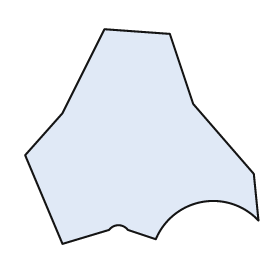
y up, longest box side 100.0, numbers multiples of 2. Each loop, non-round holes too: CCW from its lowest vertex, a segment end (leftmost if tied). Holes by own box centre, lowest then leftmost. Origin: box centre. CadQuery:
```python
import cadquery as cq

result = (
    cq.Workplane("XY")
    .moveTo(-34.0, -46.0)
    .lineTo(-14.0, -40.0)
    .threePointArc((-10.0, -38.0), (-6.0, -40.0))
    .lineTo(6.0, -44.0)
    .threePointArc((26.0, -28.0), (50.0, -36.0))
    .lineTo(48.0, -16.0)
    .lineTo(22.0, 14.0)
    .lineTo(12.0, 44.0)
    .lineTo(-16.0, 46.0)
    .lineTo(-34.0, 10.0)
    .lineTo(-50.0, -8.0)
    .close()
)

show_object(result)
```